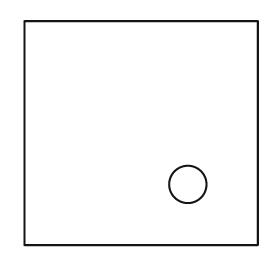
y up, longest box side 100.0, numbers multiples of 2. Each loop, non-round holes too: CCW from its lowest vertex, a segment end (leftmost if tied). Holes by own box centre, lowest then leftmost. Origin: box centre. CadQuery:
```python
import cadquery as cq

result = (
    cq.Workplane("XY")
    .moveTo(-50.0, -48.0)
    .lineTo(50.0, -48.0)
    .lineTo(50.0, 48.0)
    .lineTo(-50.0, 48.0)
    .close()
    .moveTo(20.0, -22.0)
    .circle(8.0)
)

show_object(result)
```